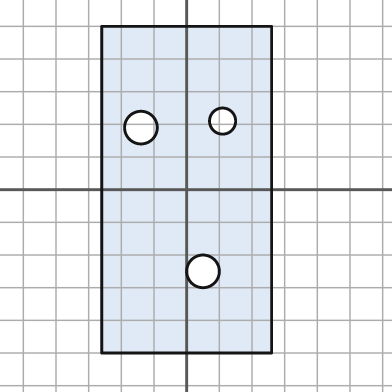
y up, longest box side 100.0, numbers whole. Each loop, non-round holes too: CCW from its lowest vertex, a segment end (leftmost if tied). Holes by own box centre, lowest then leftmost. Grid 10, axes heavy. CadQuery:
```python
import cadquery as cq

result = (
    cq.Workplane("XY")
    .moveTo(-26.0, -50.0)
    .lineTo(26.0, -50.0)
    .lineTo(26.0, 50.0)
    .lineTo(-26.0, 50.0)
    .close()
    .moveTo(5.0, -25.0)
    .circle(5.0)
    .moveTo(-14.0, 19.0)
    .circle(5.0)
    .moveTo(11.0, 21.0)
    .circle(4.0)
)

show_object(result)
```